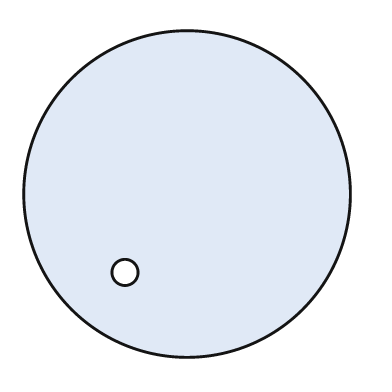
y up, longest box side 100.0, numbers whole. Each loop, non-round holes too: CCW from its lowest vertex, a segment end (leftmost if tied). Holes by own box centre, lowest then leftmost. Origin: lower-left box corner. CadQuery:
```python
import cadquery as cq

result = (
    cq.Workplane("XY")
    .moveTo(50.0, 50.0)
    .circle(50.0)
    .moveTo(31.0, 26.0)
    .circle(4.0)
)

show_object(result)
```